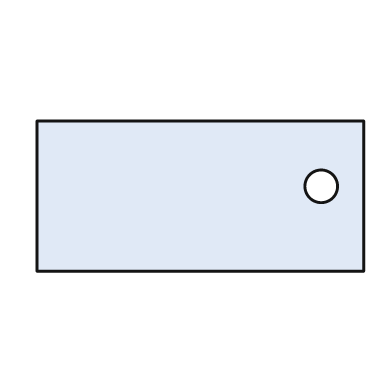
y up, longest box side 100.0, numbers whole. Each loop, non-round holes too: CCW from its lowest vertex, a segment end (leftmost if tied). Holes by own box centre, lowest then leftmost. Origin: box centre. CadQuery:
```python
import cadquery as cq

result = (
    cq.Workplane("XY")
    .moveTo(-50.0, -23.0)
    .lineTo(50.0, -23.0)
    .lineTo(50.0, 23.0)
    .lineTo(-50.0, 23.0)
    .close()
    .moveTo(37.0, 3.0)
    .circle(5.0)
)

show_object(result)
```